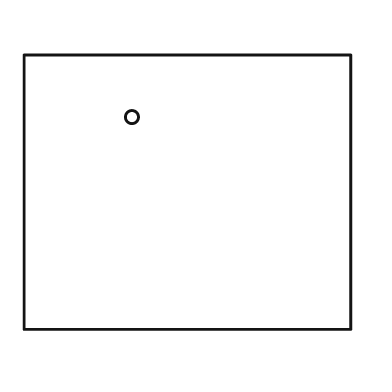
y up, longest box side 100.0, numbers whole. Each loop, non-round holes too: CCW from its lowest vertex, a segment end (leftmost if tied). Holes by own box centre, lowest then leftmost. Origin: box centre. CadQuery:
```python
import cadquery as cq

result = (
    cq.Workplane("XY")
    .moveTo(-50.0, -42.0)
    .lineTo(50.0, -42.0)
    .lineTo(50.0, 42.0)
    .lineTo(-50.0, 42.0)
    .close()
    .moveTo(-17.0, 23.0)
    .circle(2.0)
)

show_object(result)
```